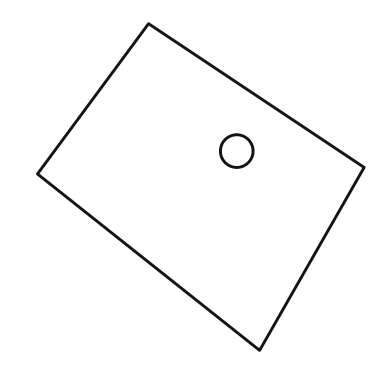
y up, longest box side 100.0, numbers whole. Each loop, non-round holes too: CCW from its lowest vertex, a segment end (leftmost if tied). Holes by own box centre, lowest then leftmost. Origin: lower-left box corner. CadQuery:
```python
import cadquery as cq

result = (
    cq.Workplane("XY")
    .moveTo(68.0, 0.0)
    .lineTo(100.0, 56.0)
    .lineTo(34.0, 100.0)
    .lineTo(0.0, 54.0)
    .close()
    .moveTo(61.0, 61.0)
    .circle(5.0)
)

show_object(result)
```